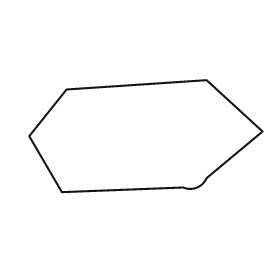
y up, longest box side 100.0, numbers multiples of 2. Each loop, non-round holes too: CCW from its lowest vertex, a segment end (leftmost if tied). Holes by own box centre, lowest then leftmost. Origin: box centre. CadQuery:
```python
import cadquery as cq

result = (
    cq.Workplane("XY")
    .moveTo(-36.0, -24.0)
    .lineTo(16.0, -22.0)
    .threePointArc((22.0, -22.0), (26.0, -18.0))
    .lineTo(50.0, 2.0)
    .lineTo(26.0, 24.0)
    .lineTo(-34.0, 20.0)
    .lineTo(-50.0, 0.0)
    .close()
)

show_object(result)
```